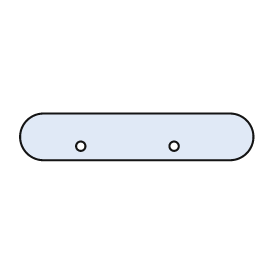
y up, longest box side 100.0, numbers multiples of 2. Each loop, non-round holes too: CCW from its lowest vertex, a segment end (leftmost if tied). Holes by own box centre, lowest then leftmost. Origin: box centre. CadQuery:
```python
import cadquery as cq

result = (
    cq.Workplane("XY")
    .moveTo(-40.0, -10.0)
    .lineTo(40.0, -10.0)
    .threePointArc((50.0, 0.0), (40.0, 10.0))
    .lineTo(-40.0, 10.0)
    .threePointArc((-50.0, 0.0), (-40.0, -10.0))
    .close()
    .moveTo(-24.0, -4.0)
    .circle(2.0)
    .moveTo(16.0, -4.0)
    .circle(2.0)
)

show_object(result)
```